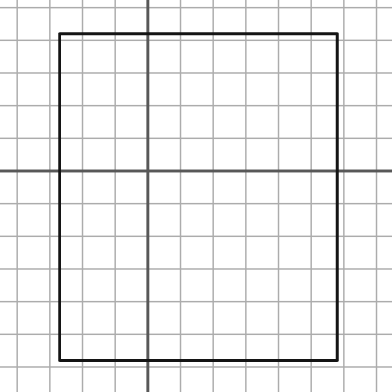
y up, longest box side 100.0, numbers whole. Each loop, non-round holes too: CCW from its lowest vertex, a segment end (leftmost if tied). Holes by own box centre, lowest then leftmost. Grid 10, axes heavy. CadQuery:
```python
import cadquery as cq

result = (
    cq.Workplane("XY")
    .moveTo(-27.0, -58.0)
    .lineTo(58.0, -58.0)
    .lineTo(58.0, 42.0)
    .lineTo(-27.0, 42.0)
    .close()
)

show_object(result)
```